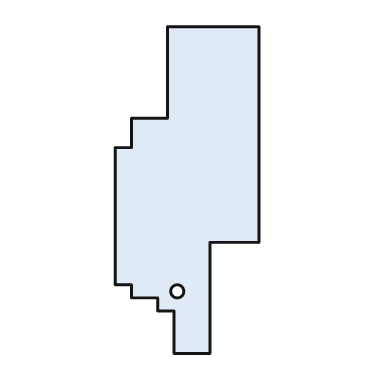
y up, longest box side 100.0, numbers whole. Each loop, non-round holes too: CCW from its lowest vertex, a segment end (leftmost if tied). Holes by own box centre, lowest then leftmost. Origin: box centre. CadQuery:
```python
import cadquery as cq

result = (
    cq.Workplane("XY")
    .moveTo(-4.0, -50.0)
    .lineTo(7.0, -50.0)
    .lineTo(7.0, -16.0)
    .lineTo(22.0, -16.0)
    .lineTo(22.0, 50.0)
    .lineTo(-6.0, 50.0)
    .lineTo(-6.0, 22.0)
    .lineTo(-17.0, 22.0)
    .lineTo(-17.0, 13.0)
    .lineTo(-22.0, 13.0)
    .lineTo(-22.0, -29.0)
    .lineTo(-17.0, -29.0)
    .lineTo(-17.0, -33.0)
    .lineTo(-9.0, -33.0)
    .lineTo(-9.0, -37.0)
    .lineTo(-4.0, -37.0)
    .close()
    .moveTo(-3.0, -31.0)
    .circle(2.0)
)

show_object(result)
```